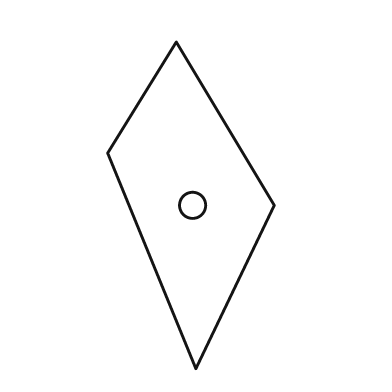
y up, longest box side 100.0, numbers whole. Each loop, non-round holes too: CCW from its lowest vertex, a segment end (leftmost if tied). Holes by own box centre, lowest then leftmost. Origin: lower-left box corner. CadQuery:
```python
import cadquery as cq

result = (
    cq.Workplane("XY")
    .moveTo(27.0, 0.0)
    .lineTo(51.0, 50.0)
    .lineTo(21.0, 100.0)
    .lineTo(0.0, 66.0)
    .close()
    .moveTo(26.0, 50.0)
    .circle(4.0)
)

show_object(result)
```